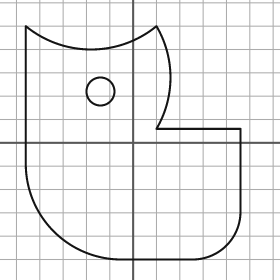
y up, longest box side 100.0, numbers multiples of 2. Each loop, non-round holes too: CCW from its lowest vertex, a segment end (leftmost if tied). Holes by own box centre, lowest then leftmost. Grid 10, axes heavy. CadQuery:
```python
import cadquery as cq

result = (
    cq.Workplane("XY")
    .moveTo(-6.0, -50.0)
    .lineTo(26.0, -50.0)
    .threePointArc((40.0, -44.0), (46.0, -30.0))
    .lineTo(46.0, 6.0)
    .lineTo(10.0, 6.0)
    .threePointArc((16.0, 28.0), (10.0, 50.0))
    .threePointArc((-18.0, 40.0), (-46.0, 50.0))
    .lineTo(-46.0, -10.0)
    .threePointArc((-34.0, -38.0), (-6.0, -50.0))
    .close()
    .moveTo(-14.0, 22.0)
    .circle(6.0)
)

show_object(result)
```